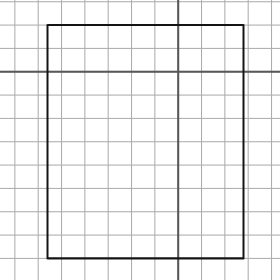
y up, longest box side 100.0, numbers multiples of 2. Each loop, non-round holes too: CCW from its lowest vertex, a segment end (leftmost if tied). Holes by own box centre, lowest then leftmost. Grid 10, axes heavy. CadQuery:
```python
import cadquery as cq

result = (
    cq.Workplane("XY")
    .moveTo(-56.0, -80.0)
    .lineTo(28.0, -80.0)
    .lineTo(28.0, 20.0)
    .lineTo(-56.0, 20.0)
    .close()
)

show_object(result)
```